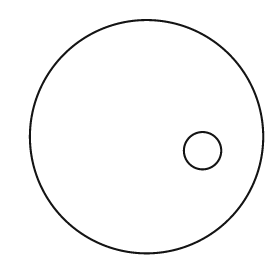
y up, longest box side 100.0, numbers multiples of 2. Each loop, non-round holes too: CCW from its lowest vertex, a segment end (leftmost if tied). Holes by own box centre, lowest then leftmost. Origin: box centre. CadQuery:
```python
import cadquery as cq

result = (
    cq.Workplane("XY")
    .moveTo(0.0, 0.0)
    .circle(50.0)
    .moveTo(24.0, -6.0)
    .circle(8.0)
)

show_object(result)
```